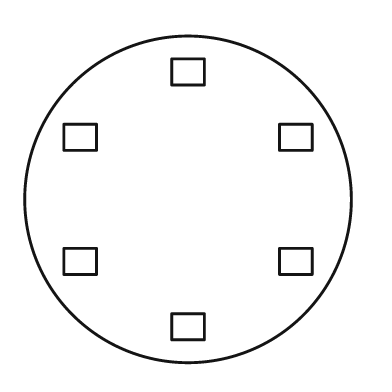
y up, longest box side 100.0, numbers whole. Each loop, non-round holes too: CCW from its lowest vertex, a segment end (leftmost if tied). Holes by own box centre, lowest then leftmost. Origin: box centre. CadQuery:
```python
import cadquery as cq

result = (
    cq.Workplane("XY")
    .moveTo(0.0, 0.0)
    .circle(50.0)
    .moveTo(-5.0, -43.0)
    .lineTo(5.0, -43.0)
    .lineTo(5.0, -35.0)
    .lineTo(-5.0, -35.0)
    .close()
    .moveTo(-38.0, -23.0)
    .lineTo(-28.0, -23.0)
    .lineTo(-28.0, -15.0)
    .lineTo(-38.0, -15.0)
    .close()
    .moveTo(28.0, -23.0)
    .lineTo(38.0, -23.0)
    .lineTo(38.0, -15.0)
    .lineTo(28.0, -15.0)
    .close()
    .moveTo(-38.0, 15.0)
    .lineTo(-28.0, 15.0)
    .lineTo(-28.0, 23.0)
    .lineTo(-38.0, 23.0)
    .close()
    .moveTo(28.0, 15.0)
    .lineTo(38.0, 15.0)
    .lineTo(38.0, 23.0)
    .lineTo(28.0, 23.0)
    .close()
    .moveTo(-5.0, 35.0)
    .lineTo(5.0, 35.0)
    .lineTo(5.0, 43.0)
    .lineTo(-5.0, 43.0)
    .close()
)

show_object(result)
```